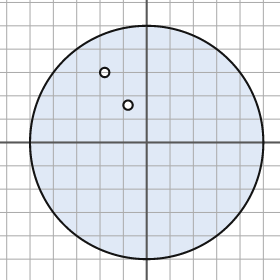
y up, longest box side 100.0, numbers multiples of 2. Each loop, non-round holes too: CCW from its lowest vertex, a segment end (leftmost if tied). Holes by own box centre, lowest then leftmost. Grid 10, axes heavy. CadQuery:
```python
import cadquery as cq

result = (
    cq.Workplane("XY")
    .moveTo(0.0, 0.0)
    .circle(50.0)
    .moveTo(-8.0, 16.0)
    .circle(2.0)
    .moveTo(-18.0, 30.0)
    .circle(2.0)
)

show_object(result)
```